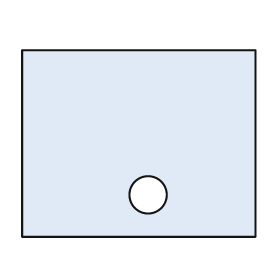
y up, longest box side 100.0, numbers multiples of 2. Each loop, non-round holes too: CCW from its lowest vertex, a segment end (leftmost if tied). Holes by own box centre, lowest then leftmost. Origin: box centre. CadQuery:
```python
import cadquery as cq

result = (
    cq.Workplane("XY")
    .moveTo(-50.0, -40.0)
    .lineTo(50.0, -40.0)
    .lineTo(50.0, 40.0)
    .lineTo(-50.0, 40.0)
    .close()
    .moveTo(4.0, -22.0)
    .circle(8.0)
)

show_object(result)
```